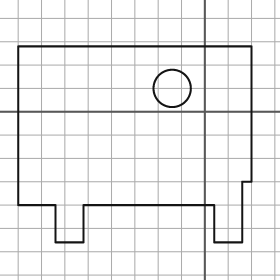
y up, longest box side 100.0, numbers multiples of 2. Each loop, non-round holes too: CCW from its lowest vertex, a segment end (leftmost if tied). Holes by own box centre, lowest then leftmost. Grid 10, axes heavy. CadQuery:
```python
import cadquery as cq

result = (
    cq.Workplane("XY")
    .moveTo(-64.0, -56.0)
    .lineTo(-52.0, -56.0)
    .lineTo(-52.0, -40.0)
    .lineTo(4.0, -40.0)
    .lineTo(4.0, -56.0)
    .lineTo(16.0, -56.0)
    .lineTo(16.0, -30.0)
    .lineTo(20.0, -30.0)
    .lineTo(20.0, 28.0)
    .lineTo(-80.0, 28.0)
    .lineTo(-80.0, -40.0)
    .lineTo(-64.0, -40.0)
    .close()
    .moveTo(-14.0, 10.0)
    .circle(8.0)
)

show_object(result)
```